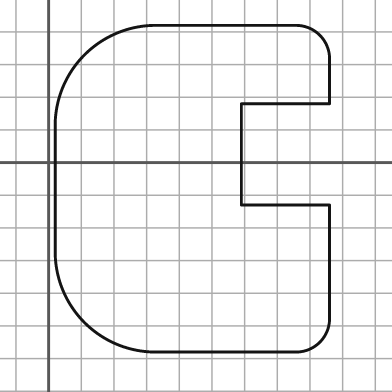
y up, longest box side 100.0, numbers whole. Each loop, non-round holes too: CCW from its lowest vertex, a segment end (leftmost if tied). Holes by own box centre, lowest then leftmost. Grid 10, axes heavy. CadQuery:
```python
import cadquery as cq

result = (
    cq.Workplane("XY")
    .moveTo(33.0, -58.0)
    .lineTo(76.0, -58.0)
    .threePointArc((83.0, -55.0), (86.0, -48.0))
    .lineTo(86.0, -13.0)
    .lineTo(59.0, -13.0)
    .lineTo(59.0, 18.0)
    .lineTo(86.0, 18.0)
    .lineTo(86.0, 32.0)
    .threePointArc((83.0, 39.0), (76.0, 42.0))
    .lineTo(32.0, 42.0)
    .threePointArc((11.0, 33.0), (2.0, 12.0))
    .lineTo(2.0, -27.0)
    .threePointArc((11.0, -49.0), (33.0, -58.0))
    .close()
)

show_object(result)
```